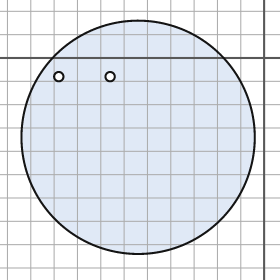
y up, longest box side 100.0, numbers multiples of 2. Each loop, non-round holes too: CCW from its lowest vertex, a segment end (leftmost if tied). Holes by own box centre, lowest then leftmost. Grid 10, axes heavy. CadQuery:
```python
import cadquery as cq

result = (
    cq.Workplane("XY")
    .moveTo(-54.0, -34.0)
    .circle(50.0)
    .moveTo(-88.0, -8.0)
    .circle(2.0)
    .moveTo(-66.0, -8.0)
    .circle(2.0)
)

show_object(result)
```